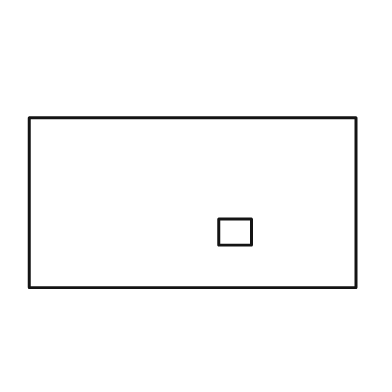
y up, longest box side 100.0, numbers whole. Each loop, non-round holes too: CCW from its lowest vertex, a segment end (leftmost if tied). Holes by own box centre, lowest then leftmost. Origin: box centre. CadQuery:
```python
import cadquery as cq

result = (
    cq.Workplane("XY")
    .moveTo(-50.0, -26.0)
    .lineTo(50.0, -26.0)
    .lineTo(50.0, 26.0)
    .lineTo(-50.0, 26.0)
    .close()
    .moveTo(8.0, -13.0)
    .lineTo(18.0, -13.0)
    .lineTo(18.0, -5.0)
    .lineTo(8.0, -5.0)
    .close()
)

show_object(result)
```